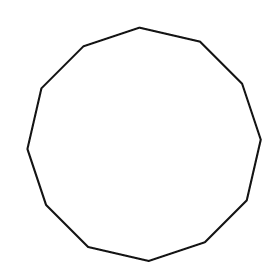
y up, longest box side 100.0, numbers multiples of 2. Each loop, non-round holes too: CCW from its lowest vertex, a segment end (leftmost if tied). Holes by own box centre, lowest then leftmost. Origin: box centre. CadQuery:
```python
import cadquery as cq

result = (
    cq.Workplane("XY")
    .moveTo(2.0, -50.0)
    .lineTo(26.0, -42.0)
    .lineTo(44.0, -24.0)
    .lineTo(50.0, 2.0)
    .lineTo(42.0, 26.0)
    .lineTo(24.0, 44.0)
    .lineTo(-2.0, 50.0)
    .lineTo(-26.0, 42.0)
    .lineTo(-44.0, 24.0)
    .lineTo(-50.0, -2.0)
    .lineTo(-42.0, -26.0)
    .lineTo(-24.0, -44.0)
    .close()
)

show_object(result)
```